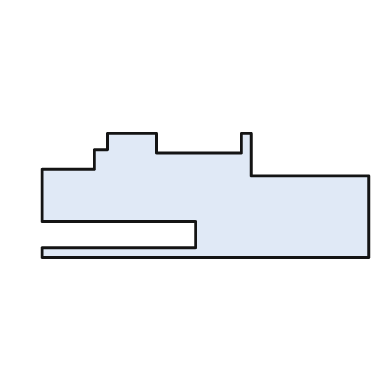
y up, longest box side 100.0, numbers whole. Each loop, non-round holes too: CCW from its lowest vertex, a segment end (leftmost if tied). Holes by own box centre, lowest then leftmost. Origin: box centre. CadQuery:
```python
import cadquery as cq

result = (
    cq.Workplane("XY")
    .moveTo(-50.0, -19.0)
    .lineTo(50.0, -19.0)
    .lineTo(50.0, 6.0)
    .lineTo(14.0, 6.0)
    .lineTo(14.0, 19.0)
    .lineTo(11.0, 19.0)
    .lineTo(11.0, 13.0)
    .lineTo(-15.0, 13.0)
    .lineTo(-15.0, 19.0)
    .lineTo(-30.0, 19.0)
    .lineTo(-30.0, 14.0)
    .lineTo(-34.0, 14.0)
    .lineTo(-34.0, 8.0)
    .lineTo(-50.0, 8.0)
    .lineTo(-50.0, -8.0)
    .lineTo(-3.0, -8.0)
    .lineTo(-3.0, -16.0)
    .lineTo(-50.0, -16.0)
    .close()
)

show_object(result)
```